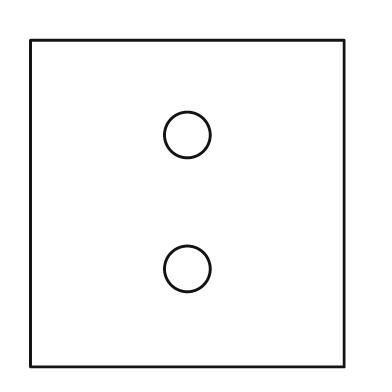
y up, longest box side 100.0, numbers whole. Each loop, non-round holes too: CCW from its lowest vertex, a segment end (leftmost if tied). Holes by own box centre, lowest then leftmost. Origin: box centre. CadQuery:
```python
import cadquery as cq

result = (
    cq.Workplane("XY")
    .moveTo(-48.0, -50.0)
    .lineTo(48.0, -50.0)
    .lineTo(48.0, 50.0)
    .lineTo(-48.0, 50.0)
    .close()
    .moveTo(0.0, -20.0)
    .circle(7.0)
    .moveTo(0.0, 21.0)
    .circle(7.0)
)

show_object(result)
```